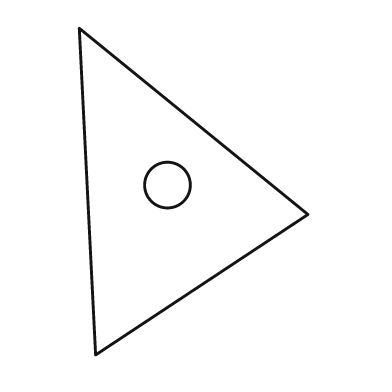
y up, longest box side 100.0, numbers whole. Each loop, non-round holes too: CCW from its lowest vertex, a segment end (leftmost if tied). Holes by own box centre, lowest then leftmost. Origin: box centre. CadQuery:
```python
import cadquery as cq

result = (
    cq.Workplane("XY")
    .moveTo(-30.0, -50.0)
    .lineTo(35.0, -7.0)
    .lineTo(-35.0, 50.0)
    .close()
    .moveTo(-8.0, 2.0)
    .circle(7.0)
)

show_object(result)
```